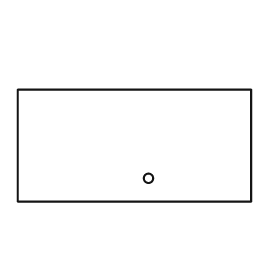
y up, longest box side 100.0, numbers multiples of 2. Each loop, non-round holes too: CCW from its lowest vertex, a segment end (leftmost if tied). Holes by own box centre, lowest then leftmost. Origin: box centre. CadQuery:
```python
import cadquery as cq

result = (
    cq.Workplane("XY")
    .moveTo(-50.0, -24.0)
    .lineTo(50.0, -24.0)
    .lineTo(50.0, 24.0)
    .lineTo(-50.0, 24.0)
    .close()
    .moveTo(6.0, -14.0)
    .circle(2.0)
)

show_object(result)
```